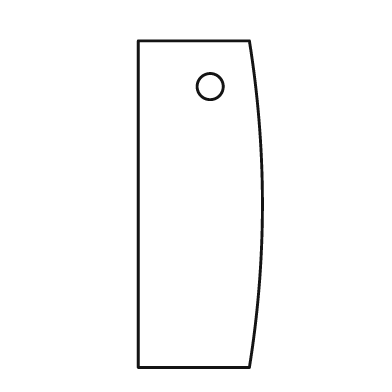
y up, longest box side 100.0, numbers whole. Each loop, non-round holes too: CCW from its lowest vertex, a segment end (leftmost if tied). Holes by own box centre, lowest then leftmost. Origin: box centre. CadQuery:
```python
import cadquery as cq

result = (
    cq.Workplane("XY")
    .moveTo(-19.0, -50.0)
    .lineTo(15.0, -50.0)
    .threePointArc((19.0, 0.0), (15.0, 50.0))
    .lineTo(-19.0, 50.0)
    .close()
    .moveTo(3.0, 36.0)
    .circle(4.0)
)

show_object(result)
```